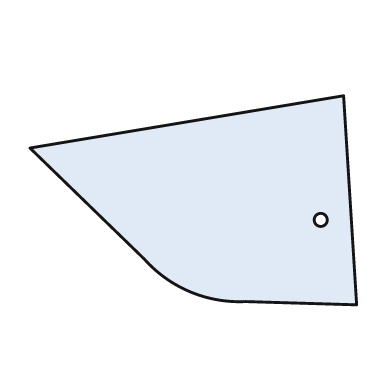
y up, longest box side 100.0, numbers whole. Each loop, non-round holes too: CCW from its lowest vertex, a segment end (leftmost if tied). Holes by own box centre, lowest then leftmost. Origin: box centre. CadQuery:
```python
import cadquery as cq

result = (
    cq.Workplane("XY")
    .moveTo(50.0, -32.0)
    .lineTo(46.0, 32.0)
    .lineTo(-50.0, 16.0)
    .lineTo(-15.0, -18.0)
    .threePointArc((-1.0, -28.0), (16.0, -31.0))
    .close()
    .moveTo(39.0, -6.0)
    .circle(2.0)
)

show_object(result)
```